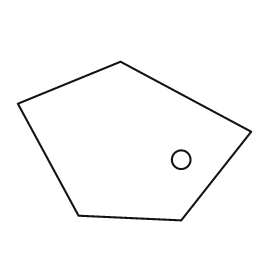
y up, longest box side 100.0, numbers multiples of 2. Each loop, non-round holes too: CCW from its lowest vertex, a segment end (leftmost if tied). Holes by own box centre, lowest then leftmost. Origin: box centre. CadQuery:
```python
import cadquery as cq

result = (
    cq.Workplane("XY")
    .moveTo(20.0, -34.0)
    .lineTo(50.0, 4.0)
    .lineTo(-6.0, 34.0)
    .lineTo(-50.0, 16.0)
    .lineTo(-24.0, -32.0)
    .close()
    .moveTo(20.0, -8.0)
    .circle(4.0)
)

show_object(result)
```